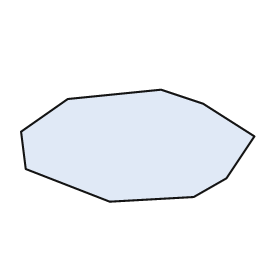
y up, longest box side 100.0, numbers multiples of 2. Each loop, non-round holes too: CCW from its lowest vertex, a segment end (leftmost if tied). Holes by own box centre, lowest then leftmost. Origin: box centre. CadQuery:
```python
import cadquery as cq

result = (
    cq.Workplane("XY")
    .moveTo(-12.0, -24.0)
    .lineTo(24.0, -22.0)
    .lineTo(38.0, -14.0)
    .lineTo(50.0, 4.0)
    .lineTo(28.0, 18.0)
    .lineTo(10.0, 24.0)
    .lineTo(-30.0, 20.0)
    .lineTo(-50.0, 6.0)
    .lineTo(-48.0, -10.0)
    .close()
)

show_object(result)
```